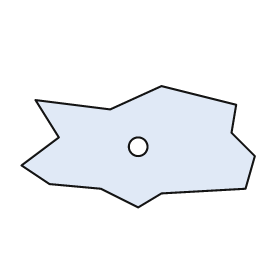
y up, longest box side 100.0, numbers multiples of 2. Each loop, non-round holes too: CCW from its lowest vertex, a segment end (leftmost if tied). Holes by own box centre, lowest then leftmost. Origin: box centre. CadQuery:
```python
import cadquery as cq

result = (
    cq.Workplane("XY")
    .moveTo(0.0, -26.0)
    .lineTo(10.0, -20.0)
    .lineTo(46.0, -18.0)
    .lineTo(50.0, -4.0)
    .lineTo(40.0, 6.0)
    .lineTo(42.0, 18.0)
    .lineTo(10.0, 26.0)
    .lineTo(-12.0, 16.0)
    .lineTo(-44.0, 20.0)
    .lineTo(-34.0, 4.0)
    .lineTo(-50.0, -8.0)
    .lineTo(-38.0, -16.0)
    .lineTo(-16.0, -18.0)
    .close()
    .moveTo(0.0, 0.0)
    .circle(4.0)
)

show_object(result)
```